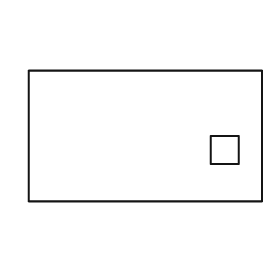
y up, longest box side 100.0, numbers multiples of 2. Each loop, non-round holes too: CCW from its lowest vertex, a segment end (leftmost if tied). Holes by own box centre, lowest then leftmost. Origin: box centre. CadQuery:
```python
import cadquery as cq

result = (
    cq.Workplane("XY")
    .moveTo(-50.0, -28.0)
    .lineTo(50.0, -28.0)
    .lineTo(50.0, 28.0)
    .lineTo(-50.0, 28.0)
    .close()
    .moveTo(28.0, -12.0)
    .lineTo(40.0, -12.0)
    .lineTo(40.0, 0.0)
    .lineTo(28.0, 0.0)
    .close()
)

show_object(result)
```